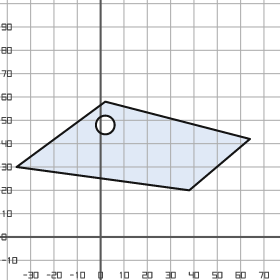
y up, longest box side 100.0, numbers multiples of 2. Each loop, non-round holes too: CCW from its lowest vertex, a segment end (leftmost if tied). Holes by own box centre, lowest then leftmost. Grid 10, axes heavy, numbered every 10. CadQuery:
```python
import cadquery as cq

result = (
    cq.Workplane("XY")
    .moveTo(38.0, 20.0)
    .lineTo(64.0, 42.0)
    .lineTo(2.0, 58.0)
    .lineTo(-36.0, 30.0)
    .close()
    .moveTo(2.0, 48.0)
    .circle(4.0)
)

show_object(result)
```